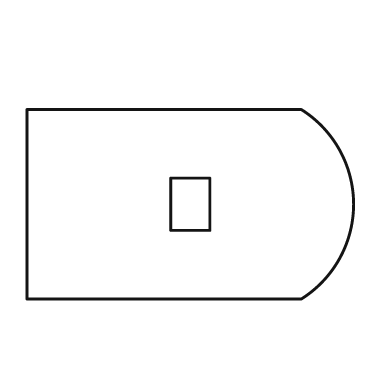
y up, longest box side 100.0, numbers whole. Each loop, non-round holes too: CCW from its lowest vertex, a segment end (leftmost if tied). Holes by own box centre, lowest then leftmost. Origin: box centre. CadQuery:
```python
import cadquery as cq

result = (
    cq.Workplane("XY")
    .moveTo(-50.0, -29.0)
    .lineTo(34.0, -29.0)
    .threePointArc((50.0, 0.0), (34.0, 29.0))
    .lineTo(-50.0, 29.0)
    .close()
    .moveTo(-6.0, -8.0)
    .lineTo(6.0, -8.0)
    .lineTo(6.0, 8.0)
    .lineTo(-6.0, 8.0)
    .close()
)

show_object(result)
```